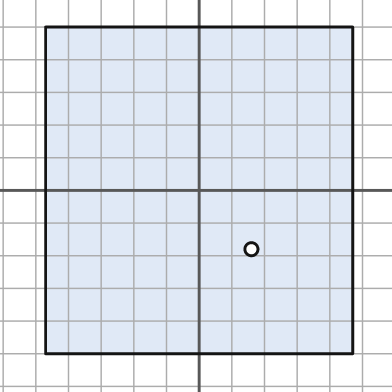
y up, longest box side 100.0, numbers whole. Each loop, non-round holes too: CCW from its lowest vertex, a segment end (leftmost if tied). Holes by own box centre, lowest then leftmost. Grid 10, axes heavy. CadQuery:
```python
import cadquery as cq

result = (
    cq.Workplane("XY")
    .moveTo(-47.0, -50.0)
    .lineTo(47.0, -50.0)
    .lineTo(47.0, 50.0)
    .lineTo(-47.0, 50.0)
    .close()
    .moveTo(16.0, -18.0)
    .circle(2.0)
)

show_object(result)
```